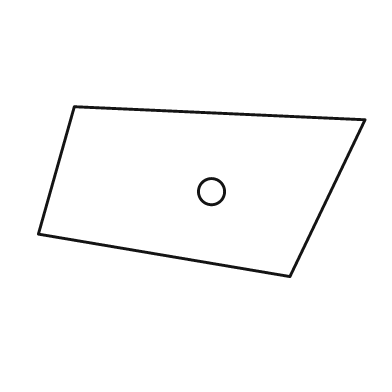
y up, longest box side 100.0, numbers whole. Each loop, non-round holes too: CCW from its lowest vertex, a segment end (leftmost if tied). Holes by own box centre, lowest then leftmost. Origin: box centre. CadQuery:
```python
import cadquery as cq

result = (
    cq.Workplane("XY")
    .moveTo(27.0, -26.0)
    .lineTo(50.0, 22.0)
    .lineTo(-39.0, 26.0)
    .lineTo(-50.0, -13.0)
    .close()
    .moveTo(3.0, 0.0)
    .circle(4.0)
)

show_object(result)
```